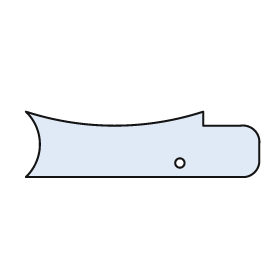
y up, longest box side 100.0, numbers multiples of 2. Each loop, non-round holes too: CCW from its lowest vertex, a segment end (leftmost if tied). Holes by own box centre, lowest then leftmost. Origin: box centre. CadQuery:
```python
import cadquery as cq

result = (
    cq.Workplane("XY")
    .moveTo(-50.0, -14.0)
    .lineTo(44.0, -14.0)
    .threePointArc((48.0, -12.0), (50.0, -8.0))
    .lineTo(50.0, 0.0)
    .threePointArc((48.0, 6.0), (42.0, 8.0))
    .lineTo(26.0, 8.0)
    .lineTo(26.0, 14.0)
    .threePointArc((-12.0, 8.0), (-50.0, 14.0))
    .threePointArc((-44.0, 0.0), (-50.0, -14.0))
    .close()
    .moveTo(16.0, -8.0)
    .circle(2.0)
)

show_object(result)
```